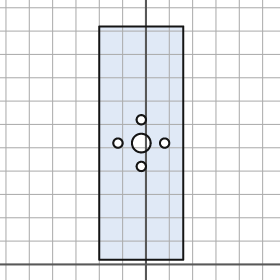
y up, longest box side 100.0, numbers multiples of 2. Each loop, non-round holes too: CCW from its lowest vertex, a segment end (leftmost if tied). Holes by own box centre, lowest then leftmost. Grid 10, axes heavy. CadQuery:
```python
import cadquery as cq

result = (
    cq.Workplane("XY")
    .moveTo(-20.0, 2.0)
    .lineTo(16.0, 2.0)
    .lineTo(16.0, 102.0)
    .lineTo(-20.0, 102.0)
    .close()
    .moveTo(-2.0, 42.0)
    .circle(2.0)
    .moveTo(-12.0, 52.0)
    .circle(2.0)
    .moveTo(-2.0, 52.0)
    .circle(4.0)
    .moveTo(8.0, 52.0)
    .circle(2.0)
    .moveTo(-2.0, 62.0)
    .circle(2.0)
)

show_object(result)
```